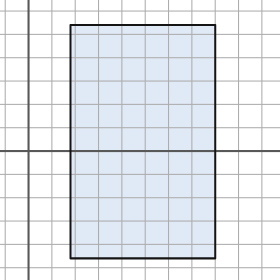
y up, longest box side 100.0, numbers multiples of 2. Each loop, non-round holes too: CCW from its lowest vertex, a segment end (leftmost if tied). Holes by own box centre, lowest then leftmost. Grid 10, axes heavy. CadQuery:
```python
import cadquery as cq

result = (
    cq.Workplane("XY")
    .moveTo(18.0, -46.0)
    .lineTo(80.0, -46.0)
    .lineTo(80.0, 54.0)
    .lineTo(18.0, 54.0)
    .close()
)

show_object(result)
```